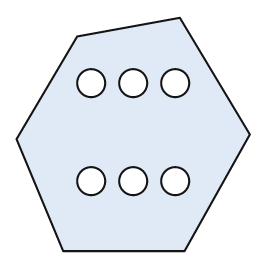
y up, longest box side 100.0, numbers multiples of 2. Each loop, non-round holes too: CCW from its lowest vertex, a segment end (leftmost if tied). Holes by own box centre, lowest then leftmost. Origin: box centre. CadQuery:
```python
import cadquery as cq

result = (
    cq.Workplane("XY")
    .moveTo(-30.0, -50.0)
    .lineTo(22.0, -50.0)
    .lineTo(50.0, 0.0)
    .lineTo(20.0, 50.0)
    .lineTo(-24.0, 42.0)
    .lineTo(-50.0, -2.0)
    .close()
    .moveTo(-18.0, -20.0)
    .circle(6.0)
    .moveTo(0.0, -20.0)
    .circle(6.0)
    .moveTo(18.0, -20.0)
    .circle(6.0)
    .moveTo(-18.0, 22.0)
    .circle(6.0)
    .moveTo(0.0, 22.0)
    .circle(6.0)
    .moveTo(18.0, 22.0)
    .circle(6.0)
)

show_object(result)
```